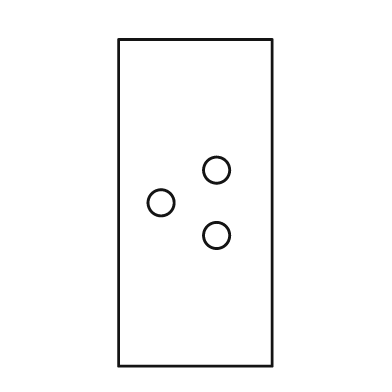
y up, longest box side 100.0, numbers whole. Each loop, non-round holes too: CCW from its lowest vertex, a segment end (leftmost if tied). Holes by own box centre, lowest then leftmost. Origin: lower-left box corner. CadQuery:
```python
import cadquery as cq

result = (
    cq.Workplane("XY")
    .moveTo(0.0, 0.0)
    .lineTo(47.0, 0.0)
    .lineTo(47.0, 100.0)
    .lineTo(0.0, 100.0)
    .close()
    .moveTo(30.0, 40.0)
    .circle(4.0)
    .moveTo(13.0, 50.0)
    .circle(4.0)
    .moveTo(30.0, 60.0)
    .circle(4.0)
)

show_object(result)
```